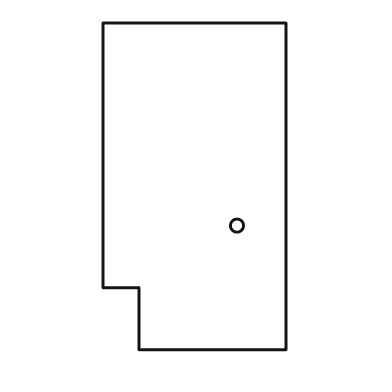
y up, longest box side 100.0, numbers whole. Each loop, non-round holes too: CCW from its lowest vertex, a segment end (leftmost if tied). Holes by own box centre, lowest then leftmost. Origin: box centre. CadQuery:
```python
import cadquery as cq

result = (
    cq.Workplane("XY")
    .moveTo(-17.0, -50.0)
    .lineTo(28.0, -50.0)
    .lineTo(28.0, 50.0)
    .lineTo(-28.0, 50.0)
    .lineTo(-28.0, -31.0)
    .lineTo(-17.0, -31.0)
    .close()
    .moveTo(13.0, -12.0)
    .circle(2.0)
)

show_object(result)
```